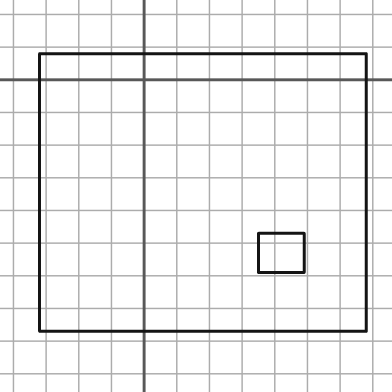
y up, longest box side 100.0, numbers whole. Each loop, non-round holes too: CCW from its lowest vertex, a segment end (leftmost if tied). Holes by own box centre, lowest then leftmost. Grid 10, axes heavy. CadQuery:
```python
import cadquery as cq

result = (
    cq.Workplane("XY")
    .moveTo(-32.0, -77.0)
    .lineTo(68.0, -77.0)
    .lineTo(68.0, 8.0)
    .lineTo(-32.0, 8.0)
    .close()
    .moveTo(35.0, -59.0)
    .lineTo(49.0, -59.0)
    .lineTo(49.0, -47.0)
    .lineTo(35.0, -47.0)
    .close()
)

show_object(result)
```